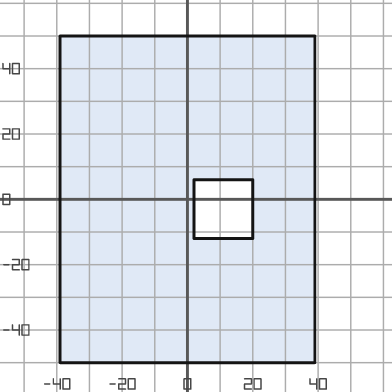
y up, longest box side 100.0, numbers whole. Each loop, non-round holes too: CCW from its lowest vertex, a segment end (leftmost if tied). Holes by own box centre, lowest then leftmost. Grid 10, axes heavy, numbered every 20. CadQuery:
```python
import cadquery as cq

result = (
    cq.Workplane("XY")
    .moveTo(-39.0, -50.0)
    .lineTo(39.0, -50.0)
    .lineTo(39.0, 50.0)
    .lineTo(-39.0, 50.0)
    .close()
    .moveTo(2.0, -12.0)
    .lineTo(20.0, -12.0)
    .lineTo(20.0, 6.0)
    .lineTo(2.0, 6.0)
    .close()
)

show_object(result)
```